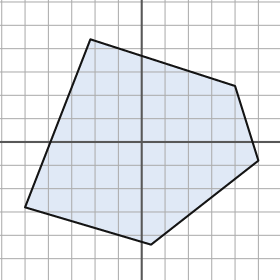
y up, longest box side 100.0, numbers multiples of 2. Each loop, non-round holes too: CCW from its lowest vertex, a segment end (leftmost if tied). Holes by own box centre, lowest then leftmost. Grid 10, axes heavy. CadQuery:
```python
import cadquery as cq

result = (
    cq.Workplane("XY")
    .moveTo(4.0, -44.0)
    .lineTo(50.0, -8.0)
    .lineTo(40.0, 24.0)
    .lineTo(-22.0, 44.0)
    .lineTo(-50.0, -28.0)
    .close()
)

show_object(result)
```